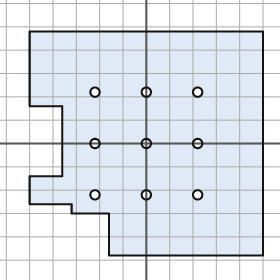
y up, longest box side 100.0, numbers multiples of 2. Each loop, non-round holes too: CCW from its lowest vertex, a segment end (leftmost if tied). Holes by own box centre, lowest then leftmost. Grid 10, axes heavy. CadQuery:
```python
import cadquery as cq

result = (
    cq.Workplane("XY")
    .moveTo(-16.0, -48.0)
    .lineTo(50.0, -48.0)
    .lineTo(50.0, 48.0)
    .lineTo(-50.0, 48.0)
    .lineTo(-50.0, 16.0)
    .lineTo(-36.0, 16.0)
    .lineTo(-36.0, -14.0)
    .lineTo(-50.0, -14.0)
    .lineTo(-50.0, -26.0)
    .lineTo(-32.0, -26.0)
    .lineTo(-32.0, -30.0)
    .lineTo(-16.0, -30.0)
    .close()
    .moveTo(-22.0, -22.0)
    .circle(2.0)
    .moveTo(0.0, -22.0)
    .circle(2.0)
    .moveTo(22.0, -22.0)
    .circle(2.0)
    .moveTo(-22.0, 0.0)
    .circle(2.0)
    .moveTo(0.0, 0.0)
    .circle(2.0)
    .moveTo(22.0, 0.0)
    .circle(2.0)
    .moveTo(-22.0, 22.0)
    .circle(2.0)
    .moveTo(0.0, 22.0)
    .circle(2.0)
    .moveTo(22.0, 22.0)
    .circle(2.0)
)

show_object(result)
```